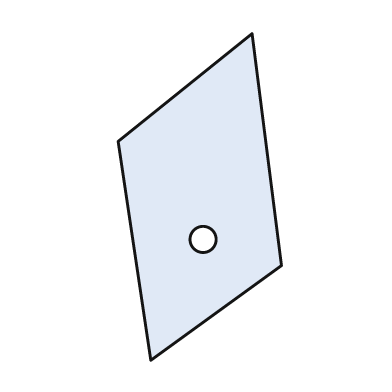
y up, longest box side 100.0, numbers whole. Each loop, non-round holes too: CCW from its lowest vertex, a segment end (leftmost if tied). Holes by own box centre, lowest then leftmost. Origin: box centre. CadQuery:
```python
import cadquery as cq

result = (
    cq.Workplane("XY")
    .moveTo(-15.0, -50.0)
    .lineTo(25.0, -21.0)
    .lineTo(16.0, 50.0)
    .lineTo(-25.0, 17.0)
    .close()
    .moveTo(1.0, -13.0)
    .circle(4.0)
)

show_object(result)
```